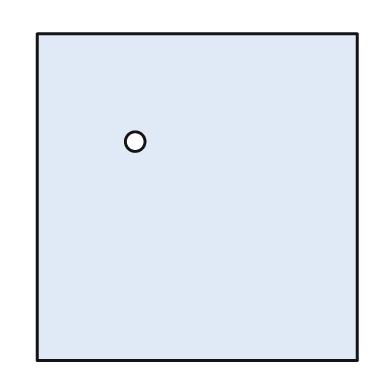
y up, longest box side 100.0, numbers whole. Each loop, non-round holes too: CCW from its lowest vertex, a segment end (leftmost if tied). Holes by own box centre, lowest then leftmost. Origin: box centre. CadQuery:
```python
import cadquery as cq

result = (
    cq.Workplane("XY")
    .moveTo(-49.0, -50.0)
    .lineTo(49.0, -50.0)
    .lineTo(49.0, 50.0)
    .lineTo(-49.0, 50.0)
    .close()
    .moveTo(-19.0, 17.0)
    .circle(3.0)
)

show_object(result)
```